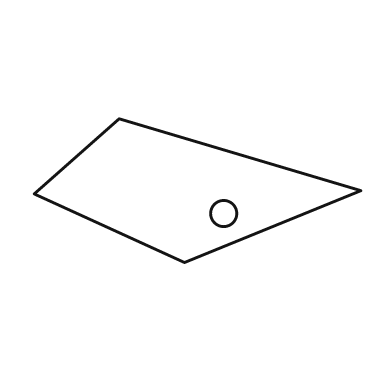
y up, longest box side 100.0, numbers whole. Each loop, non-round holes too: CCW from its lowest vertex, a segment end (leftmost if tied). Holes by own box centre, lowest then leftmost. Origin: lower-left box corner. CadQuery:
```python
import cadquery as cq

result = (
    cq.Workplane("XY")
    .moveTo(46.0, 0.0)
    .lineTo(100.0, 22.0)
    .lineTo(26.0, 44.0)
    .lineTo(0.0, 21.0)
    .close()
    .moveTo(58.0, 15.0)
    .circle(4.0)
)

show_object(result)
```